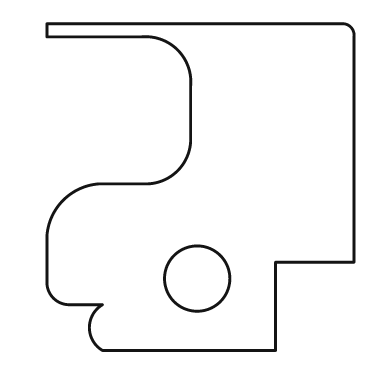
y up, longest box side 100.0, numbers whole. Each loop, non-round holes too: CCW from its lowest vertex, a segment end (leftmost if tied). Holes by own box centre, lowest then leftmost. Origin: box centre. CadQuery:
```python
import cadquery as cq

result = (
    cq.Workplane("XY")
    .moveTo(-30.0, -50.0)
    .lineTo(23.0, -50.0)
    .lineTo(23.0, -23.0)
    .lineTo(47.0, -23.0)
    .lineTo(47.0, 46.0)
    .threePointArc((46.0, 49.0), (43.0, 50.0))
    .lineTo(-47.0, 50.0)
    .lineTo(-47.0, 46.0)
    .lineTo(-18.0, 46.0)
    .threePointArc((-7.0, 42.0), (-3.0, 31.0))
    .lineTo(-3.0, 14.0)
    .threePointArc((-7.0, 5.0), (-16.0, 1.0))
    .lineTo(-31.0, 1.0)
    .threePointArc((-42.0, -4.0), (-47.0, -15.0))
    .lineTo(-47.0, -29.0)
    .threePointArc((-45.0, -34.0), (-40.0, -36.0))
    .lineTo(-30.0, -36.0)
    .threePointArc((-34.0, -43.0), (-30.0, -50.0))
    .close()
    .moveTo(-1.0, -28.0)
    .circle(10.0)
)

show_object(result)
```